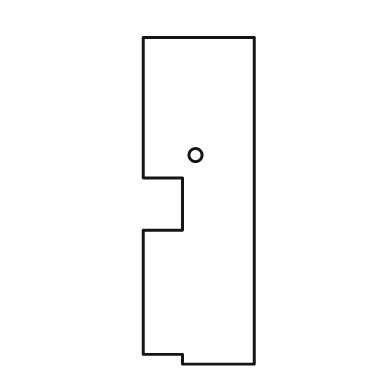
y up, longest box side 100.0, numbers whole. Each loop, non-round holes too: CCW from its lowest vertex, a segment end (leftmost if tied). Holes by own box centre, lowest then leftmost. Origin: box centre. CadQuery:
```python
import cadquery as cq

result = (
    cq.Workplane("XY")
    .moveTo(-5.0, -50.0)
    .lineTo(17.0, -50.0)
    .lineTo(17.0, 50.0)
    .lineTo(-17.0, 50.0)
    .lineTo(-17.0, 7.0)
    .lineTo(-5.0, 7.0)
    .lineTo(-5.0, -9.0)
    .lineTo(-17.0, -9.0)
    .lineTo(-17.0, -47.0)
    .lineTo(-5.0, -47.0)
    .close()
    .moveTo(-1.0, 14.0)
    .circle(2.0)
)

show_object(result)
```